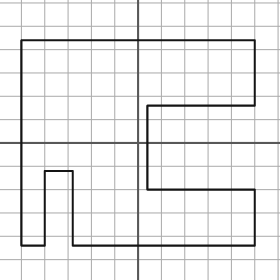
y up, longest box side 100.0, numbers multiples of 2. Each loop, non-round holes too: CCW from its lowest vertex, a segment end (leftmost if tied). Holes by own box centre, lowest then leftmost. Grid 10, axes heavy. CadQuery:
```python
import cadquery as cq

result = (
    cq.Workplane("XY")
    .moveTo(-50.0, -44.0)
    .lineTo(-40.0, -44.0)
    .lineTo(-40.0, -12.0)
    .lineTo(-28.0, -12.0)
    .lineTo(-28.0, -44.0)
    .lineTo(50.0, -44.0)
    .lineTo(50.0, -20.0)
    .lineTo(4.0, -20.0)
    .lineTo(4.0, 16.0)
    .lineTo(50.0, 16.0)
    .lineTo(50.0, 44.0)
    .lineTo(-50.0, 44.0)
    .close()
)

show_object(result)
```